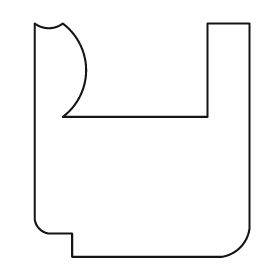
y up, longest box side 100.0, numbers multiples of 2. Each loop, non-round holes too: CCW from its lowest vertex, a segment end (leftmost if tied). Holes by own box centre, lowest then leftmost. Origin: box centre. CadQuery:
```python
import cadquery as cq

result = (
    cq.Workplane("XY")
    .moveTo(-30.0, -50.0)
    .lineTo(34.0, -50.0)
    .threePointArc((42.0, -46.0), (46.0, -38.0))
    .lineTo(46.0, 50.0)
    .lineTo(28.0, 50.0)
    .lineTo(28.0, 10.0)
    .lineTo(-34.0, 10.0)
    .threePointArc((-24.0, 30.0), (-34.0, 50.0))
    .threePointArc((-40.0, 48.0), (-46.0, 50.0))
    .lineTo(-46.0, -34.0)
    .threePointArc((-44.0, -38.0), (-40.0, -40.0))
    .lineTo(-30.0, -40.0)
    .close()
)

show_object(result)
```